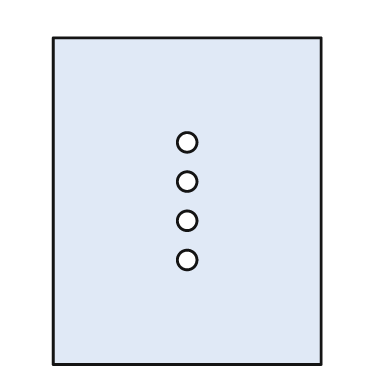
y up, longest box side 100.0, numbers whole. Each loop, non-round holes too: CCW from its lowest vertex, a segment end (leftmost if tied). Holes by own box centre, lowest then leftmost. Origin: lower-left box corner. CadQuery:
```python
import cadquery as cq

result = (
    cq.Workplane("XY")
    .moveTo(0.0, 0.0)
    .lineTo(82.0, 0.0)
    .lineTo(82.0, 100.0)
    .lineTo(0.0, 100.0)
    .close()
    .moveTo(41.0, 32.0)
    .circle(3.0)
    .moveTo(41.0, 44.0)
    .circle(3.0)
    .moveTo(41.0, 56.0)
    .circle(3.0)
    .moveTo(41.0, 68.0)
    .circle(3.0)
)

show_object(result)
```